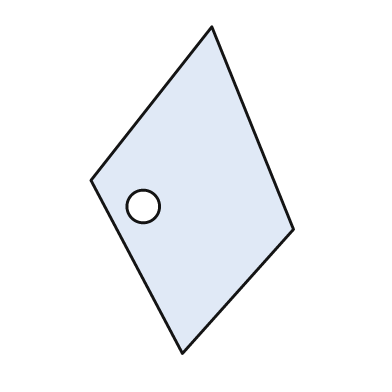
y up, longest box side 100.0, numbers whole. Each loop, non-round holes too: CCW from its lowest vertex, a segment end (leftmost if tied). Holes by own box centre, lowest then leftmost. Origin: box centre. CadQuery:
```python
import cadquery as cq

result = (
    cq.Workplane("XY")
    .moveTo(-3.0, -50.0)
    .lineTo(31.0, -12.0)
    .lineTo(6.0, 50.0)
    .lineTo(-31.0, 3.0)
    .close()
    .moveTo(-15.0, -5.0)
    .circle(5.0)
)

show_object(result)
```